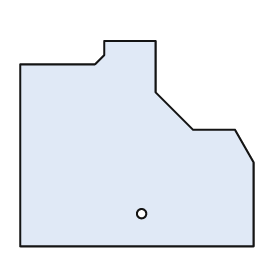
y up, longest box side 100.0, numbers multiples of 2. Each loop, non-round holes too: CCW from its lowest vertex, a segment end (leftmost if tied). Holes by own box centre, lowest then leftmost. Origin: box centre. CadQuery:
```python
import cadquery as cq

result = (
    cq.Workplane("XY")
    .moveTo(-50.0, -44.0)
    .lineTo(50.0, -44.0)
    .lineTo(50.0, -8.0)
    .lineTo(42.0, 6.0)
    .lineTo(24.0, 6.0)
    .lineTo(8.0, 22.0)
    .lineTo(8.0, 44.0)
    .lineTo(-14.0, 44.0)
    .lineTo(-14.0, 38.0)
    .lineTo(-18.0, 34.0)
    .lineTo(-50.0, 34.0)
    .close()
    .moveTo(2.0, -30.0)
    .circle(2.0)
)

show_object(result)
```